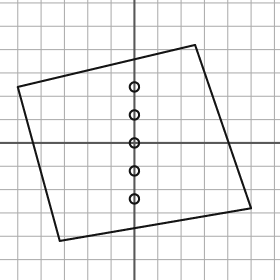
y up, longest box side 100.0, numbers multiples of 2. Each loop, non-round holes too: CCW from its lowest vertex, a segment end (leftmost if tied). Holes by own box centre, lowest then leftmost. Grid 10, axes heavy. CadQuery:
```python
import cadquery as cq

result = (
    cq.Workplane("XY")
    .moveTo(-32.0, -42.0)
    .lineTo(50.0, -28.0)
    .lineTo(26.0, 42.0)
    .lineTo(-50.0, 24.0)
    .close()
    .moveTo(0.0, -24.0)
    .circle(2.0)
    .moveTo(0.0, -12.0)
    .circle(2.0)
    .moveTo(0.0, 0.0)
    .circle(2.0)
    .moveTo(0.0, 12.0)
    .circle(2.0)
    .moveTo(0.0, 24.0)
    .circle(2.0)
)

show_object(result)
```